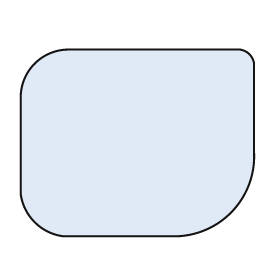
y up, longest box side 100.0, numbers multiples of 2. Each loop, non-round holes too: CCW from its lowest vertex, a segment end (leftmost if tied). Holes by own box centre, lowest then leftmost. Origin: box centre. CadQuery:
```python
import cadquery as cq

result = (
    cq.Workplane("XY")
    .moveTo(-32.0, -40.0)
    .lineTo(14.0, -40.0)
    .threePointArc((40.0, -30.0), (50.0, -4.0))
    .lineTo(50.0, 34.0)
    .threePointArc((48.0, 38.0), (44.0, 40.0))
    .lineTo(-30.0, 40.0)
    .threePointArc((-44.0, 34.0), (-50.0, 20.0))
    .lineTo(-50.0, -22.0)
    .threePointArc((-44.0, -34.0), (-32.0, -40.0))
    .close()
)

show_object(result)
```